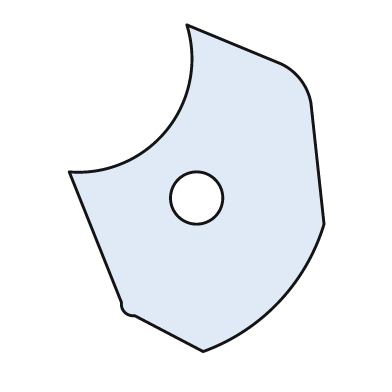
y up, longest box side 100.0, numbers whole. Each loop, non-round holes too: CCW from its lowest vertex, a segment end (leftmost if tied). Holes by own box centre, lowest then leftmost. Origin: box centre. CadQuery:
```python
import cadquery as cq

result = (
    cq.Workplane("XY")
    .moveTo(2.0, -50.0)
    .threePointArc((25.0, -35.0), (39.0, -11.0))
    .lineTo(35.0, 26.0)
    .threePointArc((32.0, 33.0), (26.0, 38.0))
    .lineTo(-3.0, 50.0)
    .threePointArc((-9.0, 18.0), (-39.0, 5.0))
    .lineTo(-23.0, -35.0)
    .threePointArc((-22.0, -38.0), (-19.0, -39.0))
    .close()
    .moveTo(0.0, -3.0)
    .circle(8.0)
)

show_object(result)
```